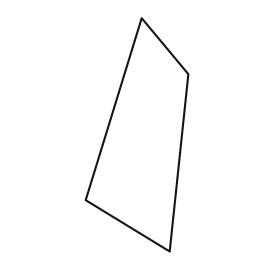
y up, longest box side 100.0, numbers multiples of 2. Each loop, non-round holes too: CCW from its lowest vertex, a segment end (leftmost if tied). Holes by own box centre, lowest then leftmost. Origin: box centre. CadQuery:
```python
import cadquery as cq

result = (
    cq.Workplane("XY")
    .moveTo(14.0, -50.0)
    .lineTo(22.0, 26.0)
    .lineTo(2.0, 50.0)
    .lineTo(-22.0, -28.0)
    .close()
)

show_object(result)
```